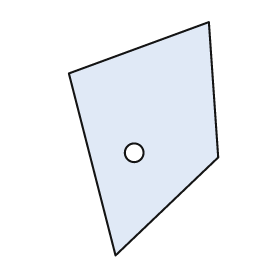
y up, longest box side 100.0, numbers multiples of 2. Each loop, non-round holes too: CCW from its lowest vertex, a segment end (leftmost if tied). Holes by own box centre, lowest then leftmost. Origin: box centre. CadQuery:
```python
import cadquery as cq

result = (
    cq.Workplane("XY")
    .moveTo(-12.0, -50.0)
    .lineTo(32.0, -8.0)
    .lineTo(28.0, 50.0)
    .lineTo(-32.0, 28.0)
    .close()
    .moveTo(-4.0, -6.0)
    .circle(4.0)
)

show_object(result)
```